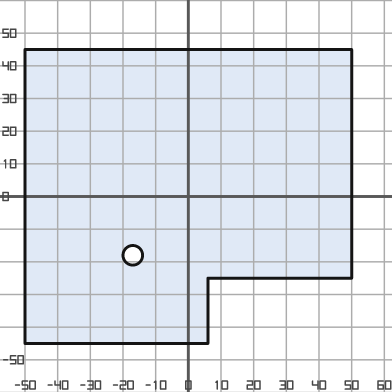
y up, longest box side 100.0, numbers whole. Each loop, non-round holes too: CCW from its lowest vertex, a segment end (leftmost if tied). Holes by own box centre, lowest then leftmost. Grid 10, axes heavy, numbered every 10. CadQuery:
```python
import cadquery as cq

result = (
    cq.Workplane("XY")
    .moveTo(-50.0, -45.0)
    .lineTo(6.0, -45.0)
    .lineTo(6.0, -25.0)
    .lineTo(50.0, -25.0)
    .lineTo(50.0, 45.0)
    .lineTo(-50.0, 45.0)
    .close()
    .moveTo(-17.0, -18.0)
    .circle(3.0)
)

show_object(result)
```